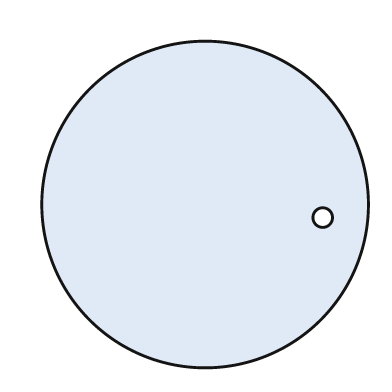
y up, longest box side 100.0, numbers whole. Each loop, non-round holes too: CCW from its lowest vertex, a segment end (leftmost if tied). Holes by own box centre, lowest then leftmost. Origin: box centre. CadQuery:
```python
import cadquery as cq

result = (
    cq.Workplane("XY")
    .moveTo(0.0, 0.0)
    .circle(50.0)
    .moveTo(36.0, -4.0)
    .circle(3.0)
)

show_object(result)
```